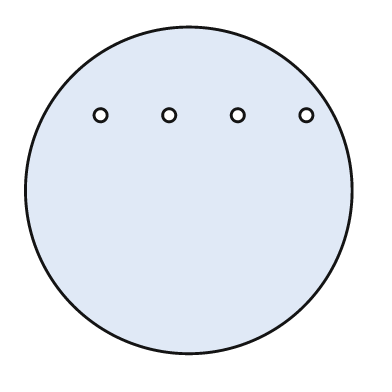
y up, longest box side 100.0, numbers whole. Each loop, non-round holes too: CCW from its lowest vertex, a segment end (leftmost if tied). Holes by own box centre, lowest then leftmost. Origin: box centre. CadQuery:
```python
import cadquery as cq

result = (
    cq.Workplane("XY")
    .moveTo(0.0, 0.0)
    .circle(50.0)
    .moveTo(-27.0, 23.0)
    .circle(2.0)
    .moveTo(-6.0, 23.0)
    .circle(2.0)
    .moveTo(15.0, 23.0)
    .circle(2.0)
    .moveTo(36.0, 23.0)
    .circle(2.0)
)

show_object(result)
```